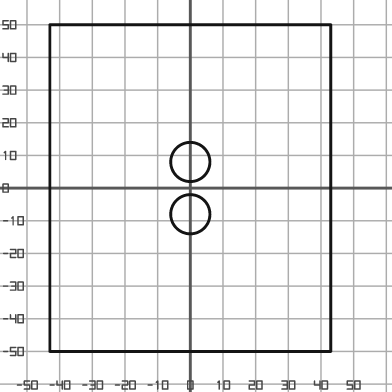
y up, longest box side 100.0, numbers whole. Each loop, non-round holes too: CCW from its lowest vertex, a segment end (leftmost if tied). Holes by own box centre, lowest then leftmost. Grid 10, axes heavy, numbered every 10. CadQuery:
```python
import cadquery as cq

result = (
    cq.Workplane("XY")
    .moveTo(-43.0, -50.0)
    .lineTo(43.0, -50.0)
    .lineTo(43.0, 50.0)
    .lineTo(-43.0, 50.0)
    .close()
    .moveTo(0.0, -8.0)
    .circle(6.0)
    .moveTo(0.0, 8.0)
    .circle(6.0)
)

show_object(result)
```